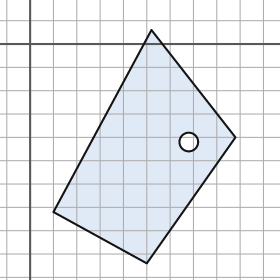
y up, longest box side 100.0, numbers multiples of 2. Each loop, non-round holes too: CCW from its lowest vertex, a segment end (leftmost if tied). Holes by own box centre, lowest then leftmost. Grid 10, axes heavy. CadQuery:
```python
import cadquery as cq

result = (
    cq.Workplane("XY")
    .moveTo(50.0, -94.0)
    .lineTo(88.0, -40.0)
    .lineTo(52.0, 6.0)
    .lineTo(10.0, -72.0)
    .close()
    .moveTo(68.0, -42.0)
    .circle(4.0)
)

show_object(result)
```